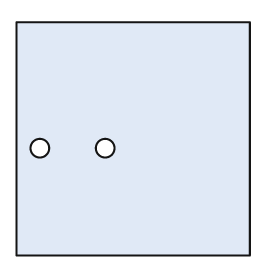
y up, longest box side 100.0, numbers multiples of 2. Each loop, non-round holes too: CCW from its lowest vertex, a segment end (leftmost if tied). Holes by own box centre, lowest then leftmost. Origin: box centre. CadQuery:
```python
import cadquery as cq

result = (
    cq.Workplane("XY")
    .moveTo(-50.0, -50.0)
    .lineTo(50.0, -50.0)
    .lineTo(50.0, 50.0)
    .lineTo(-50.0, 50.0)
    .close()
    .moveTo(-40.0, -4.0)
    .circle(4.0)
    .moveTo(-12.0, -4.0)
    .circle(4.0)
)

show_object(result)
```